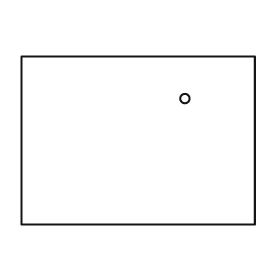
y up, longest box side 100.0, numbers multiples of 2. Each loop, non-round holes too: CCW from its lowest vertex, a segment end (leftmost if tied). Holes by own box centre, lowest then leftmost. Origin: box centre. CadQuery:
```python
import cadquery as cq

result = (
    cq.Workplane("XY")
    .moveTo(-50.0, -36.0)
    .lineTo(50.0, -36.0)
    .lineTo(50.0, 36.0)
    .lineTo(-50.0, 36.0)
    .close()
    .moveTo(20.0, 18.0)
    .circle(2.0)
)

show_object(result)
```